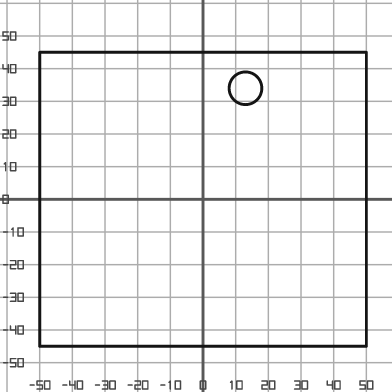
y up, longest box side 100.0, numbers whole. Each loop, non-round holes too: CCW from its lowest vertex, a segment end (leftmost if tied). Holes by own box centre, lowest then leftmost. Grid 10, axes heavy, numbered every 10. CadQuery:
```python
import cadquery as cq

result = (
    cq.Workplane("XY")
    .moveTo(-50.0, -45.0)
    .lineTo(50.0, -45.0)
    .lineTo(50.0, 45.0)
    .lineTo(-50.0, 45.0)
    .close()
    .moveTo(13.0, 34.0)
    .circle(5.0)
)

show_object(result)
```